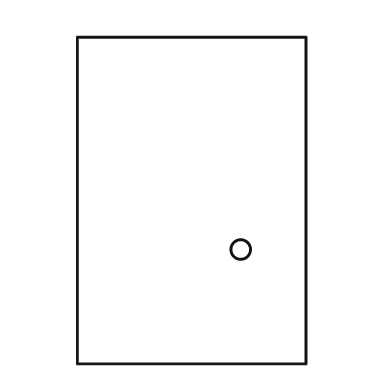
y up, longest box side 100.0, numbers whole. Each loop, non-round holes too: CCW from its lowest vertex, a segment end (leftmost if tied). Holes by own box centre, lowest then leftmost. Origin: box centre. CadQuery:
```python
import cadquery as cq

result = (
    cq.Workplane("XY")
    .moveTo(-35.0, -50.0)
    .lineTo(35.0, -50.0)
    .lineTo(35.0, 50.0)
    .lineTo(-35.0, 50.0)
    .close()
    .moveTo(15.0, -15.0)
    .circle(3.0)
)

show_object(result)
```